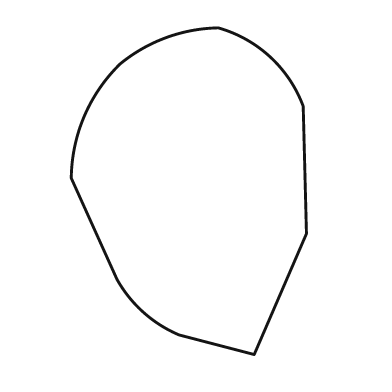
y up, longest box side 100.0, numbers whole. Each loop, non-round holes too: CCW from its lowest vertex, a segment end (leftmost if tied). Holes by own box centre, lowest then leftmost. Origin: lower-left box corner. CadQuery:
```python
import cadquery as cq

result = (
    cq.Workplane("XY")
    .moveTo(56.0, 0.0)
    .lineTo(72.0, 37.0)
    .lineTo(71.0, 76.0)
    .threePointArc((61.0, 91.0), (45.0, 100.0))
    .threePointArc((29.0, 97.0), (15.0, 89.0))
    .threePointArc((4.0, 73.0), (0.0, 54.0))
    .lineTo(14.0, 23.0)
    .threePointArc((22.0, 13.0), (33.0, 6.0))
    .close()
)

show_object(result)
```